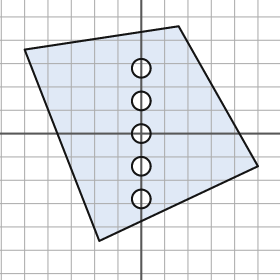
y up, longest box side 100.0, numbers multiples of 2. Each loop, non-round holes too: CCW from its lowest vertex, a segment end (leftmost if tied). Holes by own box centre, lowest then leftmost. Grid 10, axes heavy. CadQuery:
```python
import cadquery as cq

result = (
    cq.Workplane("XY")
    .moveTo(-18.0, -46.0)
    .lineTo(50.0, -14.0)
    .lineTo(16.0, 46.0)
    .lineTo(-50.0, 36.0)
    .close()
    .moveTo(0.0, -28.0)
    .circle(4.0)
    .moveTo(0.0, -14.0)
    .circle(4.0)
    .moveTo(0.0, 0.0)
    .circle(4.0)
    .moveTo(0.0, 14.0)
    .circle(4.0)
    .moveTo(0.0, 28.0)
    .circle(4.0)
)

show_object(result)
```